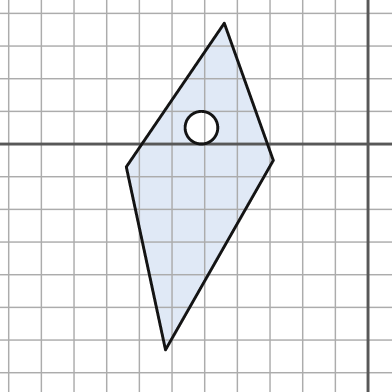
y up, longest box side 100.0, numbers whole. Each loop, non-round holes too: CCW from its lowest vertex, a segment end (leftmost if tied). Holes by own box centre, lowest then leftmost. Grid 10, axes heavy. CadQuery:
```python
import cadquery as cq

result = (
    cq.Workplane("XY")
    .moveTo(-62.0, -63.0)
    .lineTo(-29.0, -5.0)
    .lineTo(-44.0, 37.0)
    .lineTo(-74.0, -7.0)
    .close()
    .moveTo(-51.0, 5.0)
    .circle(5.0)
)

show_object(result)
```